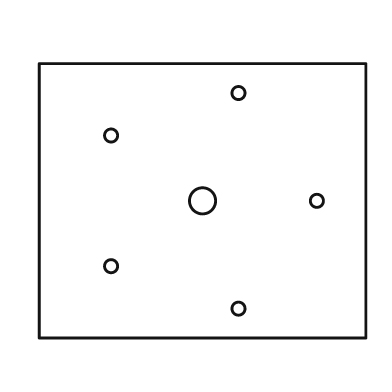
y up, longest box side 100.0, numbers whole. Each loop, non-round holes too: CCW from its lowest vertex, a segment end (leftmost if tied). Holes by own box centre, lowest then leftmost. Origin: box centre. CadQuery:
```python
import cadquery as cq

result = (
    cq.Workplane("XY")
    .moveTo(-50.0, -42.0)
    .lineTo(50.0, -42.0)
    .lineTo(50.0, 42.0)
    .lineTo(-50.0, 42.0)
    .close()
    .moveTo(11.0, -33.0)
    .circle(2.0)
    .moveTo(-28.0, -20.0)
    .circle(2.0)
    .moveTo(0.0, 0.0)
    .circle(4.0)
    .moveTo(35.0, 0.0)
    .circle(2.0)
    .moveTo(-28.0, 20.0)
    .circle(2.0)
    .moveTo(11.0, 33.0)
    .circle(2.0)
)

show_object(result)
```